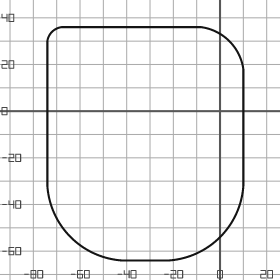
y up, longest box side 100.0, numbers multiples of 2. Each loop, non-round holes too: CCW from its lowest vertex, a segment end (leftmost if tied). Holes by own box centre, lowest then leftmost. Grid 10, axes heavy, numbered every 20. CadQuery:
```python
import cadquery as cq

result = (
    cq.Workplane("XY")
    .moveTo(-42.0, -64.0)
    .lineTo(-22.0, -64.0)
    .threePointArc((0.0, -54.0), (10.0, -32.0))
    .lineTo(10.0, 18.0)
    .threePointArc((4.0, 30.0), (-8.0, 36.0))
    .lineTo(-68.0, 36.0)
    .threePointArc((-72.0, 34.0), (-74.0, 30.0))
    .lineTo(-74.0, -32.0)
    .threePointArc((-64.0, -54.0), (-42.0, -64.0))
    .close()
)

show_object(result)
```